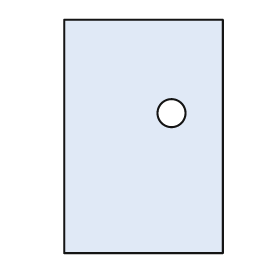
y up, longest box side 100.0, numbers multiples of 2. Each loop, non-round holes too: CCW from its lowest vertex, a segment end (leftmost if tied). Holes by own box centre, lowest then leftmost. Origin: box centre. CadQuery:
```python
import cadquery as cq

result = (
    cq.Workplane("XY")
    .moveTo(-34.0, -50.0)
    .lineTo(34.0, -50.0)
    .lineTo(34.0, 50.0)
    .lineTo(-34.0, 50.0)
    .close()
    .moveTo(12.0, 10.0)
    .circle(6.0)
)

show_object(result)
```